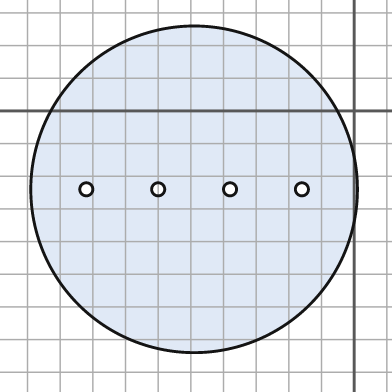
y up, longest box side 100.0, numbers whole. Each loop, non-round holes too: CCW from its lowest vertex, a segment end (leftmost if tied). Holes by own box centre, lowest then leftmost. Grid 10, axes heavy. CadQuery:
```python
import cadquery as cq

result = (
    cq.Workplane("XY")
    .moveTo(-49.0, -24.0)
    .circle(50.0)
    .moveTo(-82.0, -24.0)
    .circle(2.0)
    .moveTo(-60.0, -24.0)
    .circle(2.0)
    .moveTo(-38.0, -24.0)
    .circle(2.0)
    .moveTo(-16.0, -24.0)
    .circle(2.0)
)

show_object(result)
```